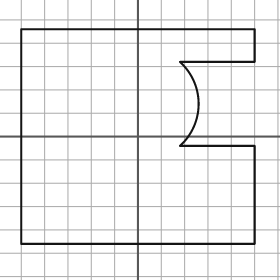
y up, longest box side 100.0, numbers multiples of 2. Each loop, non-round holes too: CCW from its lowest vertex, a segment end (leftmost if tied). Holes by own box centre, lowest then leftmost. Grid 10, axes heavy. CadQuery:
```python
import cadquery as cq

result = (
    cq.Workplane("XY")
    .moveTo(-50.0, -46.0)
    .lineTo(50.0, -46.0)
    .lineTo(50.0, -4.0)
    .lineTo(18.0, -4.0)
    .threePointArc((26.0, 14.0), (18.0, 32.0))
    .lineTo(50.0, 32.0)
    .lineTo(50.0, 46.0)
    .lineTo(-50.0, 46.0)
    .close()
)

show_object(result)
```